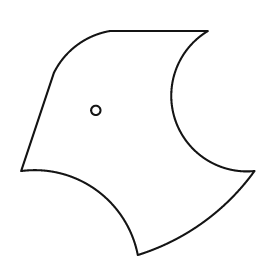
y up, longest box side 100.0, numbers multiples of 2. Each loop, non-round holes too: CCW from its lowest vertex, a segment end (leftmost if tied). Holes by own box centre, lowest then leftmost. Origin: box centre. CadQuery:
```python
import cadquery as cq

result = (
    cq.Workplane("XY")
    .moveTo(0.0, -48.0)
    .threePointArc((28.0, -34.0), (50.0, -12.0))
    .threePointArc((16.0, 10.0), (30.0, 48.0))
    .lineTo(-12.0, 48.0)
    .threePointArc((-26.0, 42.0), (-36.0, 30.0))
    .lineTo(-50.0, -12.0)
    .threePointArc((-18.0, -20.0), (0.0, -48.0))
    .close()
    .moveTo(-18.0, 14.0)
    .circle(2.0)
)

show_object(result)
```